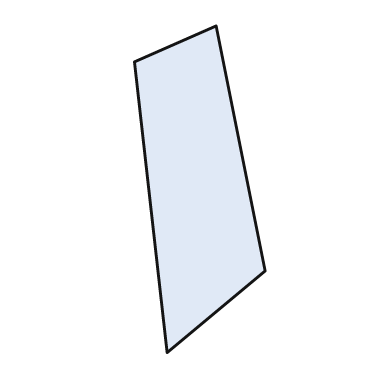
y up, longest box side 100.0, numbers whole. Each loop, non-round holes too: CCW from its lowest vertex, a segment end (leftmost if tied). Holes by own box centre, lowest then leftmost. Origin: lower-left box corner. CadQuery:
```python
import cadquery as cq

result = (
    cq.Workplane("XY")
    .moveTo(10.0, 0.0)
    .lineTo(40.0, 25.0)
    .lineTo(25.0, 100.0)
    .lineTo(0.0, 89.0)
    .close()
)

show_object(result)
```